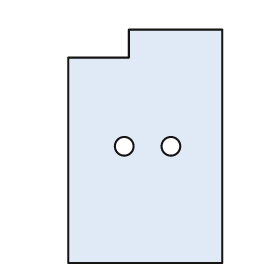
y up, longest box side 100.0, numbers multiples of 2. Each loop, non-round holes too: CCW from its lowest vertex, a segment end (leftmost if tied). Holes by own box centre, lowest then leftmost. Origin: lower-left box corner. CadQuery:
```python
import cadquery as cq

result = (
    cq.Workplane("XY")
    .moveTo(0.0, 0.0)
    .lineTo(66.0, 0.0)
    .lineTo(66.0, 100.0)
    .lineTo(26.0, 100.0)
    .lineTo(26.0, 88.0)
    .lineTo(0.0, 88.0)
    .close()
    .moveTo(24.0, 50.0)
    .circle(4.0)
    .moveTo(44.0, 50.0)
    .circle(4.0)
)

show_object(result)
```